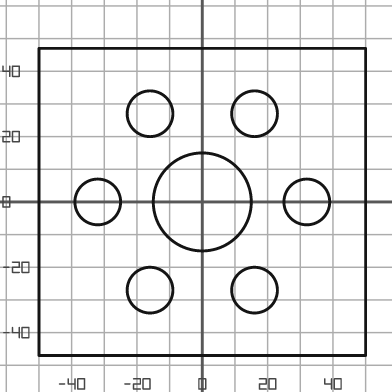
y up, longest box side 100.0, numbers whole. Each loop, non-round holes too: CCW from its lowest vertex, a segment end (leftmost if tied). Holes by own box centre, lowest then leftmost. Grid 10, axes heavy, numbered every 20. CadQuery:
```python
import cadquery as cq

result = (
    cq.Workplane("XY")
    .moveTo(-50.0, -47.0)
    .lineTo(50.0, -47.0)
    .lineTo(50.0, 47.0)
    .lineTo(-50.0, 47.0)
    .close()
    .moveTo(-16.0, -27.0)
    .circle(7.0)
    .moveTo(16.0, -27.0)
    .circle(7.0)
    .moveTo(-32.0, 0.0)
    .circle(7.0)
    .moveTo(0.0, 0.0)
    .circle(15.0)
    .moveTo(32.0, 0.0)
    .circle(7.0)
    .moveTo(-16.0, 27.0)
    .circle(7.0)
    .moveTo(16.0, 27.0)
    .circle(7.0)
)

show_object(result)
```